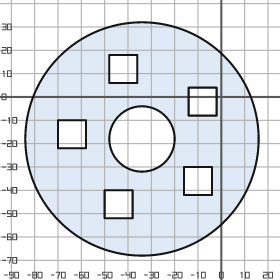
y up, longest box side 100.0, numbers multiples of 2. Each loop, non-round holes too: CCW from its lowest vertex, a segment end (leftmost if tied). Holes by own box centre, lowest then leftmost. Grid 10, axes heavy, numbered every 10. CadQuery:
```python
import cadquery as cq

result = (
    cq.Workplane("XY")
    .moveTo(-34.0, -18.0)
    .circle(50.0)
    .moveTo(-50.0, -52.0)
    .lineTo(-38.0, -52.0)
    .lineTo(-38.0, -40.0)
    .lineTo(-50.0, -40.0)
    .close()
    .moveTo(-16.0, -42.0)
    .lineTo(-4.0, -42.0)
    .lineTo(-4.0, -30.0)
    .lineTo(-16.0, -30.0)
    .close()
    .moveTo(-34.0, -18.0)
    .circle(14.0)
    .moveTo(-70.0, -22.0)
    .lineTo(-58.0, -22.0)
    .lineTo(-58.0, -10.0)
    .lineTo(-70.0, -10.0)
    .close()
    .moveTo(-14.0, -8.0)
    .lineTo(-2.0, -8.0)
    .lineTo(-2.0, 4.0)
    .lineTo(-14.0, 4.0)
    .close()
    .moveTo(-48.0, 6.0)
    .lineTo(-36.0, 6.0)
    .lineTo(-36.0, 18.0)
    .lineTo(-48.0, 18.0)
    .close()
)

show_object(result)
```